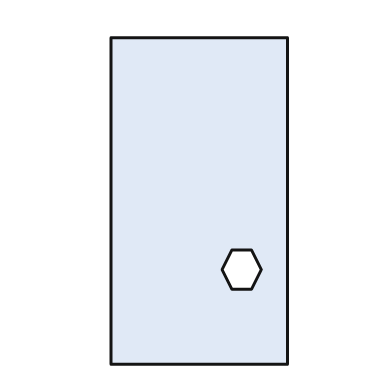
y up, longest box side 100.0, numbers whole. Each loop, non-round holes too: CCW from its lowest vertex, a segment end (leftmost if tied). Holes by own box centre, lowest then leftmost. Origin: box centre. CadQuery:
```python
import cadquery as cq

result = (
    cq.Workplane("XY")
    .moveTo(-27.0, -50.0)
    .lineTo(27.0, -50.0)
    .lineTo(27.0, 50.0)
    .lineTo(-27.0, 50.0)
    .close()
    .moveTo(10.0, -27.0)
    .lineTo(16.0, -27.0)
    .lineTo(19.0, -21.0)
    .lineTo(16.0, -15.0)
    .lineTo(10.0, -15.0)
    .lineTo(7.0, -21.0)
    .close()
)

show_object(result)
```